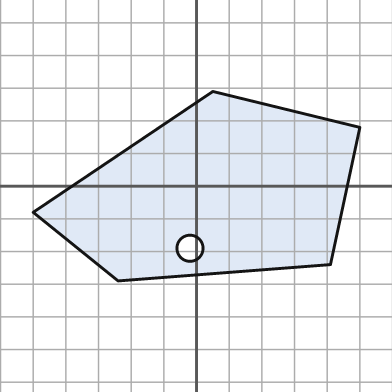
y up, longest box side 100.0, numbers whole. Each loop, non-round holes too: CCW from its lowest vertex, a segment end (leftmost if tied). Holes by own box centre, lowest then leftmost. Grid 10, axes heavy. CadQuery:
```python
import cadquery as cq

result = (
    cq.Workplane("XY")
    .moveTo(-24.0, -29.0)
    .lineTo(41.0, -24.0)
    .lineTo(50.0, 18.0)
    .lineTo(5.0, 29.0)
    .lineTo(-50.0, -8.0)
    .close()
    .moveTo(-2.0, -19.0)
    .circle(4.0)
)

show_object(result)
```